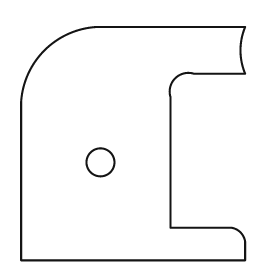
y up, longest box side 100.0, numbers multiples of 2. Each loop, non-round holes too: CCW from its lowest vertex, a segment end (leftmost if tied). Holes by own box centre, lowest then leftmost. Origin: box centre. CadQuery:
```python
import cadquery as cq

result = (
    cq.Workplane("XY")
    .moveTo(-48.0, -50.0)
    .lineTo(48.0, -50.0)
    .lineTo(48.0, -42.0)
    .threePointArc((46.0, -38.0), (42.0, -36.0))
    .lineTo(16.0, -36.0)
    .lineTo(16.0, 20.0)
    .threePointArc((18.0, 28.0), (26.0, 30.0))
    .lineTo(48.0, 30.0)
    .threePointArc((46.0, 40.0), (48.0, 50.0))
    .lineTo(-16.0, 50.0)
    .threePointArc((-38.0, 40.0), (-48.0, 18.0))
    .close()
    .moveTo(-14.0, -8.0)
    .circle(6.0)
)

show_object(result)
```